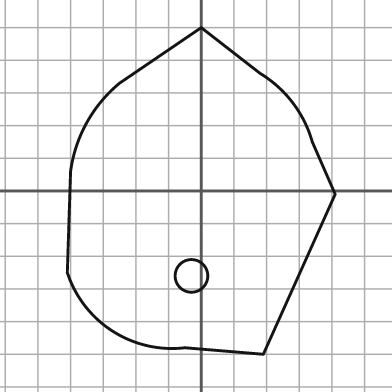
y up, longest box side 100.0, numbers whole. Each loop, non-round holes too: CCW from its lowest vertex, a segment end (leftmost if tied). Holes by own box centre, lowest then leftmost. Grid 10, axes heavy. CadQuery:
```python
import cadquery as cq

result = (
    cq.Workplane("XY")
    .moveTo(19.0, -50.0)
    .lineTo(41.0, -1.0)
    .lineTo(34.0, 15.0)
    .threePointArc((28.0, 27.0), (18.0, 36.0))
    .lineTo(0.0, 50.0)
    .lineTo(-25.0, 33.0)
    .threePointArc((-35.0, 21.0), (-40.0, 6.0))
    .lineTo(-41.0, -25.0)
    .threePointArc((-27.0, -43.0), (-5.0, -48.0))
    .close()
    .moveTo(-3.0, -26.0)
    .circle(5.0)
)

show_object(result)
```